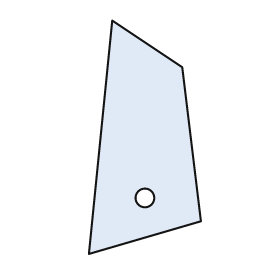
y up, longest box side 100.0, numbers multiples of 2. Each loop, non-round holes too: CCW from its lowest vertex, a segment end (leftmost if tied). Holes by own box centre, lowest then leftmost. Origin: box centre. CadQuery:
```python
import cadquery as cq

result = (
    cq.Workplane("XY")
    .moveTo(-24.0, -50.0)
    .lineTo(24.0, -36.0)
    .lineTo(16.0, 30.0)
    .lineTo(-14.0, 50.0)
    .close()
    .moveTo(0.0, -26.0)
    .circle(4.0)
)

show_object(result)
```